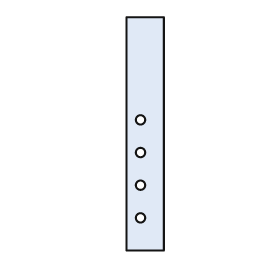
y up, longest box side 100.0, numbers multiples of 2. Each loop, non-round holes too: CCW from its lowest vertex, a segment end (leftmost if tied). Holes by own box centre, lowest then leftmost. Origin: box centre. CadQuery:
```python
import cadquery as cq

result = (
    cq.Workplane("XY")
    .moveTo(-8.0, -50.0)
    .lineTo(8.0, -50.0)
    .lineTo(8.0, 50.0)
    .lineTo(-8.0, 50.0)
    .close()
    .moveTo(-2.0, -36.0)
    .circle(2.0)
    .moveTo(-2.0, -22.0)
    .circle(2.0)
    .moveTo(-2.0, -8.0)
    .circle(2.0)
    .moveTo(-2.0, 6.0)
    .circle(2.0)
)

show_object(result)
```